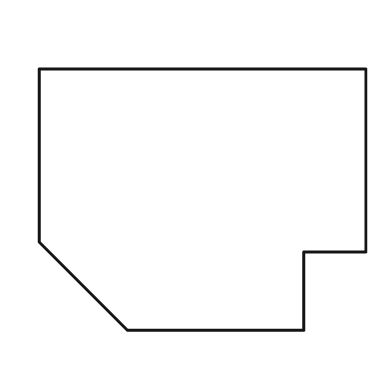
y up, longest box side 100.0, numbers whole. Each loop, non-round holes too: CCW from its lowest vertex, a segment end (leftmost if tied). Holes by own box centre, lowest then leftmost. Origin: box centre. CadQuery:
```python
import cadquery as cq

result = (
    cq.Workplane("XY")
    .moveTo(-23.0, -40.0)
    .lineTo(31.0, -40.0)
    .lineTo(31.0, -16.0)
    .lineTo(50.0, -16.0)
    .lineTo(50.0, 40.0)
    .lineTo(-50.0, 40.0)
    .lineTo(-50.0, -13.0)
    .close()
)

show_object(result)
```